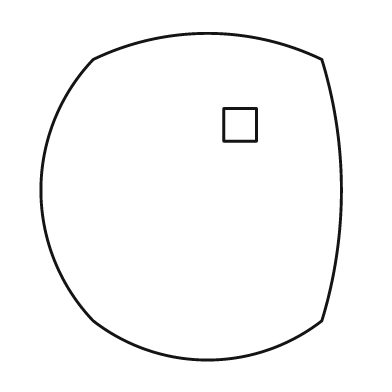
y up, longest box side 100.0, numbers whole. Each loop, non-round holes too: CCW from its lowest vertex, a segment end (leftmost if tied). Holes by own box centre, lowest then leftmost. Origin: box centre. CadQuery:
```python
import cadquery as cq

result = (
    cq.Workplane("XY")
    .moveTo(-30.0, -38.0)
    .threePointArc((5.0, -50.0), (40.0, -38.0))
    .threePointArc((46.0, 2.0), (40.0, 42.0))
    .threePointArc((5.0, 50.0), (-30.0, 42.0))
    .threePointArc((-46.0, 2.0), (-30.0, -38.0))
    .close()
    .moveTo(10.0, 17.0)
    .lineTo(20.0, 17.0)
    .lineTo(20.0, 27.0)
    .lineTo(10.0, 27.0)
    .close()
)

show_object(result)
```